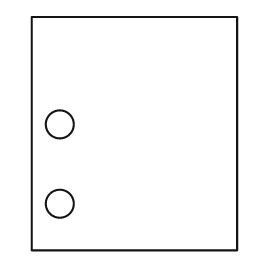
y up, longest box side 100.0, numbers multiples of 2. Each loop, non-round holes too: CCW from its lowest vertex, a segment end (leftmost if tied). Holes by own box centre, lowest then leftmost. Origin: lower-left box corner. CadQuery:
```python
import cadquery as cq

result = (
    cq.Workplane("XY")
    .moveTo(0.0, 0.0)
    .lineTo(88.0, 0.0)
    .lineTo(88.0, 100.0)
    .lineTo(0.0, 100.0)
    .close()
    .moveTo(12.0, 20.0)
    .circle(6.0)
    .moveTo(12.0, 54.0)
    .circle(6.0)
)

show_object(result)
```